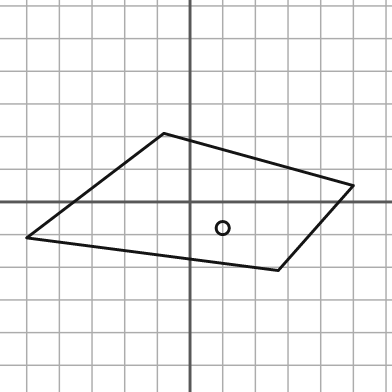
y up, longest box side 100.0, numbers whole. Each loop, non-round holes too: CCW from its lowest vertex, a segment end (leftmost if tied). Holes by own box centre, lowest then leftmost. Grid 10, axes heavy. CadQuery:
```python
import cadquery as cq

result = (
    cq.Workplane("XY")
    .moveTo(27.0, -21.0)
    .lineTo(50.0, 5.0)
    .lineTo(-8.0, 21.0)
    .lineTo(-50.0, -11.0)
    .close()
    .moveTo(10.0, -8.0)
    .circle(2.0)
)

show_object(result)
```